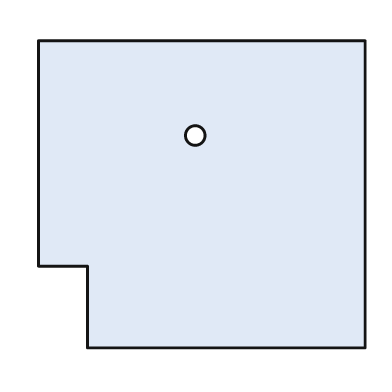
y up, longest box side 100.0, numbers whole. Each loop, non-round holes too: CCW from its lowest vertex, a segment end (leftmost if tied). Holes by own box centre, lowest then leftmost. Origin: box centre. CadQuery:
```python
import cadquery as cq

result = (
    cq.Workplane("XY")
    .moveTo(-35.0, -47.0)
    .lineTo(50.0, -47.0)
    .lineTo(50.0, 47.0)
    .lineTo(-50.0, 47.0)
    .lineTo(-50.0, -22.0)
    .lineTo(-35.0, -22.0)
    .close()
    .moveTo(-2.0, 18.0)
    .circle(3.0)
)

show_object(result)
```